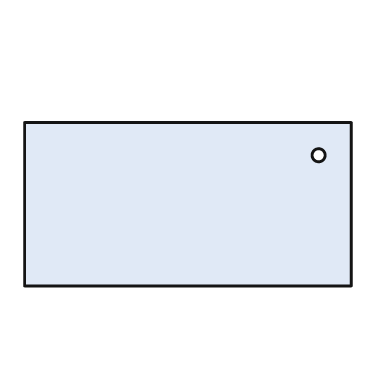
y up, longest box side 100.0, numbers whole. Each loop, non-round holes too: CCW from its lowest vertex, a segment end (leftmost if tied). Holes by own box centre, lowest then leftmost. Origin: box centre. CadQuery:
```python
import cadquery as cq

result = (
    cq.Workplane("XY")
    .moveTo(-50.0, -25.0)
    .lineTo(50.0, -25.0)
    .lineTo(50.0, 25.0)
    .lineTo(-50.0, 25.0)
    .close()
    .moveTo(40.0, 15.0)
    .circle(2.0)
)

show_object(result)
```